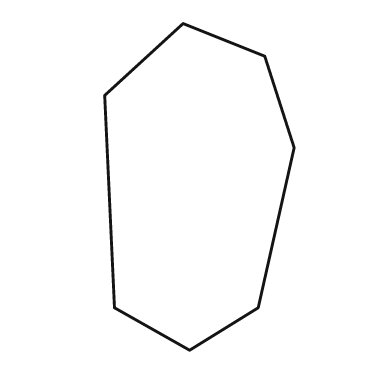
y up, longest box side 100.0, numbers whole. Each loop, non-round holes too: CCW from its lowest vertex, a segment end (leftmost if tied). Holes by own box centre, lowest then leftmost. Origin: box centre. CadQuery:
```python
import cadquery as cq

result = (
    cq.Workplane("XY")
    .moveTo(-3.0, -50.0)
    .lineTo(18.0, -37.0)
    .lineTo(29.0, 12.0)
    .lineTo(20.0, 40.0)
    .lineTo(-5.0, 50.0)
    .lineTo(-29.0, 28.0)
    .lineTo(-26.0, -37.0)
    .close()
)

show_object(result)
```